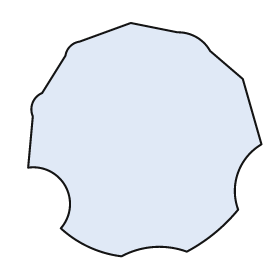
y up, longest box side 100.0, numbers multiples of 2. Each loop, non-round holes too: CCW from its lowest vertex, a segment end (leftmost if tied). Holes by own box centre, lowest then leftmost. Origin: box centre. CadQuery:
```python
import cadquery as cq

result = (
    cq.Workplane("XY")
    .moveTo(-10.0, -50.0)
    .threePointArc((4.0, -46.0), (18.0, -48.0))
    .threePointArc((30.0, -40.0), (40.0, -30.0))
    .threePointArc((40.0, -14.0), (50.0, -2.0))
    .lineTo(42.0, 26.0)
    .lineTo(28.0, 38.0)
    .threePointArc((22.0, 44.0), (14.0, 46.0))
    .lineTo(-6.0, 50.0)
    .lineTo(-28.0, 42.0)
    .threePointArc((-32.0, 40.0), (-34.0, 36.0))
    .lineTo(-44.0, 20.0)
    .threePointArc((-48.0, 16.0), (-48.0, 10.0))
    .lineTo(-50.0, -12.0)
    .threePointArc((-34.0, -20.0), (-36.0, -38.0))
    .threePointArc((-24.0, -46.0), (-10.0, -50.0))
    .close()
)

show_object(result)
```